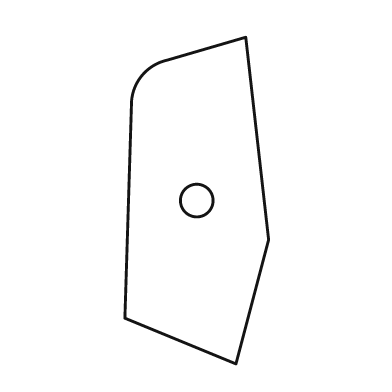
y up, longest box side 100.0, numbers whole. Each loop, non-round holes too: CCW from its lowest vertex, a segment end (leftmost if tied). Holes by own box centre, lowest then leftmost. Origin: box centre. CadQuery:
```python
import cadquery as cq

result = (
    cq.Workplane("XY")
    .moveTo(12.0, -50.0)
    .lineTo(22.0, -12.0)
    .lineTo(15.0, 50.0)
    .lineTo(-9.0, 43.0)
    .threePointArc((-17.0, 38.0), (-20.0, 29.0))
    .lineTo(-22.0, -36.0)
    .close()
    .moveTo(0.0, 0.0)
    .circle(5.0)
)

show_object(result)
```